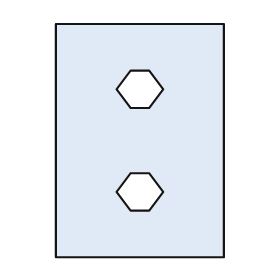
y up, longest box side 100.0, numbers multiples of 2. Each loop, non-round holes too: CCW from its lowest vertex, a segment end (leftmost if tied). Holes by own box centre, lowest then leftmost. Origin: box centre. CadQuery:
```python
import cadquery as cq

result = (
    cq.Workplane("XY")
    .moveTo(-36.0, -50.0)
    .lineTo(36.0, -50.0)
    .lineTo(36.0, 50.0)
    .lineTo(-36.0, 50.0)
    .close()
    .moveTo(-4.0, -30.0)
    .lineTo(4.0, -30.0)
    .lineTo(10.0, -22.0)
    .lineTo(4.0, -14.0)
    .lineTo(-4.0, -14.0)
    .lineTo(-10.0, -22.0)
    .close()
    .moveTo(-4.0, 14.0)
    .lineTo(4.0, 14.0)
    .lineTo(10.0, 22.0)
    .lineTo(4.0, 30.0)
    .lineTo(-4.0, 30.0)
    .lineTo(-10.0, 22.0)
    .close()
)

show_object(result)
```